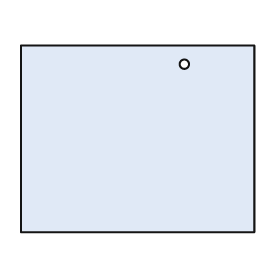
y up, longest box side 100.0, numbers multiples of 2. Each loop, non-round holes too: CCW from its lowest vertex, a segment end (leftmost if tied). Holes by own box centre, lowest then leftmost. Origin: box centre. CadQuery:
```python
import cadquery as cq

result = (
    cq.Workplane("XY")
    .moveTo(-50.0, -40.0)
    .lineTo(50.0, -40.0)
    .lineTo(50.0, 40.0)
    .lineTo(-50.0, 40.0)
    .close()
    .moveTo(20.0, 32.0)
    .circle(2.0)
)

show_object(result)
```